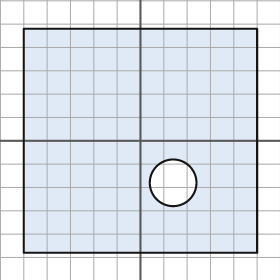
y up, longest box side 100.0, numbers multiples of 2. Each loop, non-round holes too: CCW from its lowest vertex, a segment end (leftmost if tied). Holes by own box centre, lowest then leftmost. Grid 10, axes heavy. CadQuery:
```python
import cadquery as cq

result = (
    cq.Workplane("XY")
    .moveTo(-50.0, -48.0)
    .lineTo(50.0, -48.0)
    .lineTo(50.0, 48.0)
    .lineTo(-50.0, 48.0)
    .close()
    .moveTo(14.0, -18.0)
    .circle(10.0)
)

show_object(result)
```